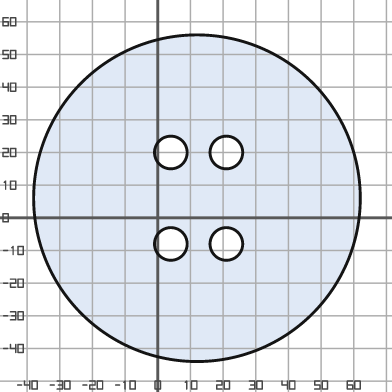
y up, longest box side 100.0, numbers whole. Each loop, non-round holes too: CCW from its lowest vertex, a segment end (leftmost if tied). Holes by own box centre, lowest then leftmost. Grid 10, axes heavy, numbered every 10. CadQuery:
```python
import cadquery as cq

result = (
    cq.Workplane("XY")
    .moveTo(12.0, 6.0)
    .circle(50.0)
    .moveTo(4.0, -8.0)
    .circle(5.0)
    .moveTo(21.0, -8.0)
    .circle(5.0)
    .moveTo(4.0, 20.0)
    .circle(5.0)
    .moveTo(21.0, 20.0)
    .circle(5.0)
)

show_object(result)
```